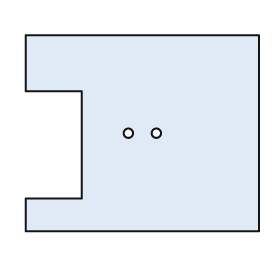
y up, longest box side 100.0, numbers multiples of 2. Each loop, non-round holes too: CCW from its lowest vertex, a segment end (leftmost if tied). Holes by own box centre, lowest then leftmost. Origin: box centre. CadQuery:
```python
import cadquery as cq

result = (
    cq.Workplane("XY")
    .moveTo(-50.0, -42.0)
    .lineTo(50.0, -42.0)
    .lineTo(50.0, 42.0)
    .lineTo(-50.0, 42.0)
    .lineTo(-50.0, 18.0)
    .lineTo(-26.0, 18.0)
    .lineTo(-26.0, -28.0)
    .lineTo(-50.0, -28.0)
    .close()
    .moveTo(-6.0, 0.0)
    .circle(2.0)
    .moveTo(6.0, 0.0)
    .circle(2.0)
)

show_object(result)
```